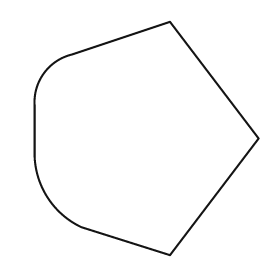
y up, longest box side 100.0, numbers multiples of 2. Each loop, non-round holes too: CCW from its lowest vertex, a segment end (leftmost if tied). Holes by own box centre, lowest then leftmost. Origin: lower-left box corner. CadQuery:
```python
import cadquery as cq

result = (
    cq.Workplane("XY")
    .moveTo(58.0, 0.0)
    .lineTo(96.0, 50.0)
    .lineTo(58.0, 100.0)
    .lineTo(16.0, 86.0)
    .threePointArc((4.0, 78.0), (0.0, 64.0))
    .lineTo(0.0, 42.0)
    .threePointArc((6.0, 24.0), (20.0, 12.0))
    .close()
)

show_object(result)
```